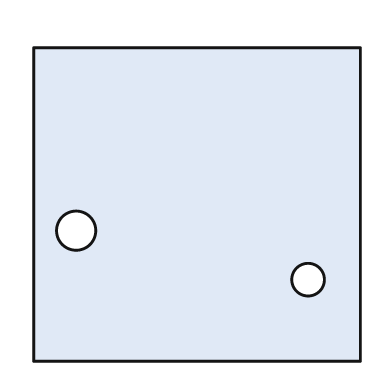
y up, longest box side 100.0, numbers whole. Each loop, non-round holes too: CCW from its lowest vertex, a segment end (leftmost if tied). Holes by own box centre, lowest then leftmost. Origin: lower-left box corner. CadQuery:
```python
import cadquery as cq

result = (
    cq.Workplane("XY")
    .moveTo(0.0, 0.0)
    .lineTo(100.0, 0.0)
    .lineTo(100.0, 96.0)
    .lineTo(0.0, 96.0)
    .close()
    .moveTo(84.0, 25.0)
    .circle(5.0)
    .moveTo(13.0, 40.0)
    .circle(6.0)
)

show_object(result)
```